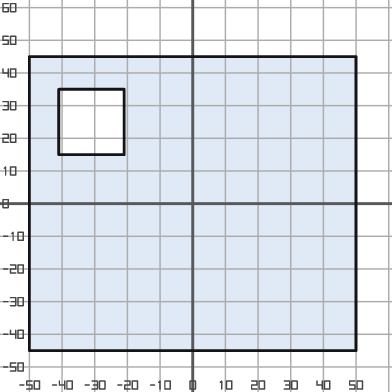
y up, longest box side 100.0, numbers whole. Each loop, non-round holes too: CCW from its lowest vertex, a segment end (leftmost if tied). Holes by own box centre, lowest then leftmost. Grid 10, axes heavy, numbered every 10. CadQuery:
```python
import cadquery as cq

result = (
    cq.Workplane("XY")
    .moveTo(-50.0, -45.0)
    .lineTo(50.0, -45.0)
    .lineTo(50.0, 45.0)
    .lineTo(-50.0, 45.0)
    .close()
    .moveTo(-41.0, 15.0)
    .lineTo(-21.0, 15.0)
    .lineTo(-21.0, 35.0)
    .lineTo(-41.0, 35.0)
    .close()
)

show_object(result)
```